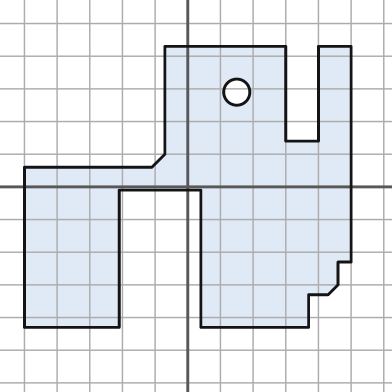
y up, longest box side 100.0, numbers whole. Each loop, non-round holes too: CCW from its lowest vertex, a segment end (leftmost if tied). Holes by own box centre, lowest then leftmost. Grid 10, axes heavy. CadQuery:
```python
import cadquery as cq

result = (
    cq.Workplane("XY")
    .moveTo(-50.0, -43.0)
    .lineTo(-21.0, -43.0)
    .lineTo(-21.0, -1.0)
    .lineTo(4.0, -1.0)
    .lineTo(4.0, -43.0)
    .lineTo(37.0, -43.0)
    .lineTo(37.0, -33.0)
    .lineTo(43.0, -33.0)
    .lineTo(46.0, -30.0)
    .lineTo(46.0, -23.0)
    .lineTo(50.0, -23.0)
    .lineTo(50.0, 43.0)
    .lineTo(40.0, 43.0)
    .lineTo(40.0, 14.0)
    .lineTo(30.0, 14.0)
    .lineTo(30.0, 43.0)
    .lineTo(-7.0, 43.0)
    .lineTo(-7.0, 10.0)
    .lineTo(-11.0, 6.0)
    .lineTo(-50.0, 6.0)
    .close()
    .moveTo(15.0, 29.0)
    .circle(4.0)
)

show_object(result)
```